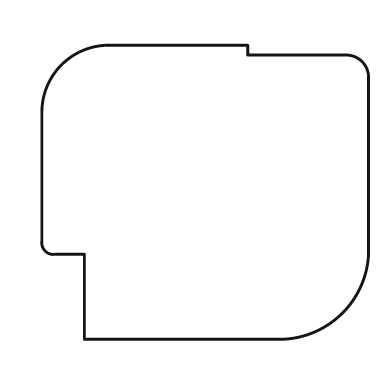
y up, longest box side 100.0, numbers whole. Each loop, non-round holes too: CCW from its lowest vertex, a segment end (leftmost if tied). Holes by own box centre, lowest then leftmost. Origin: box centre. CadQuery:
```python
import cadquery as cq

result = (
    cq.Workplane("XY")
    .moveTo(-37.0, -45.0)
    .lineTo(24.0, -45.0)
    .threePointArc((42.0, -37.0), (50.0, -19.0))
    .lineTo(50.0, 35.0)
    .threePointArc((48.0, 40.0), (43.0, 42.0))
    .lineTo(13.0, 42.0)
    .lineTo(13.0, 45.0)
    .lineTo(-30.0, 45.0)
    .threePointArc((-44.0, 39.0), (-50.0, 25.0))
    .lineTo(-50.0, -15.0)
    .threePointArc((-49.0, -18.0), (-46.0, -19.0))
    .lineTo(-37.0, -19.0)
    .close()
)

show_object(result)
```